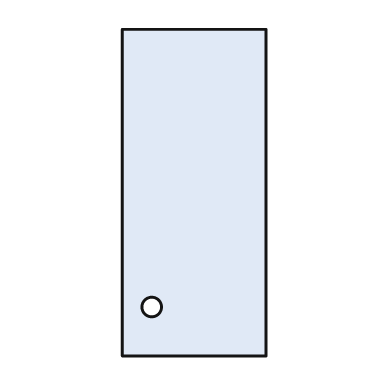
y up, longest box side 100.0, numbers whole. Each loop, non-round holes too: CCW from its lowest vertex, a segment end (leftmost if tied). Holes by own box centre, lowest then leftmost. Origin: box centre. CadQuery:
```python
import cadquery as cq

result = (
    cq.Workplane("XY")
    .moveTo(-22.0, -50.0)
    .lineTo(22.0, -50.0)
    .lineTo(22.0, 50.0)
    .lineTo(-22.0, 50.0)
    .close()
    .moveTo(-13.0, -35.0)
    .circle(3.0)
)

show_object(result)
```